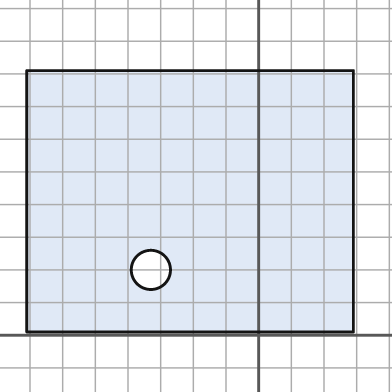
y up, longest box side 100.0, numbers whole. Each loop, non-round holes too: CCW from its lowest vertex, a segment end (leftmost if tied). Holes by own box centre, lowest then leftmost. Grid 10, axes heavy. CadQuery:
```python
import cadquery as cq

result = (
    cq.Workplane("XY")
    .moveTo(-71.0, 1.0)
    .lineTo(29.0, 1.0)
    .lineTo(29.0, 81.0)
    .lineTo(-71.0, 81.0)
    .close()
    .moveTo(-33.0, 20.0)
    .circle(6.0)
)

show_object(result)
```